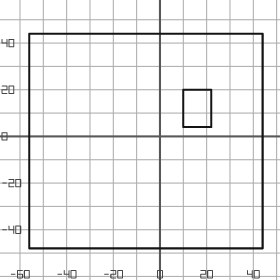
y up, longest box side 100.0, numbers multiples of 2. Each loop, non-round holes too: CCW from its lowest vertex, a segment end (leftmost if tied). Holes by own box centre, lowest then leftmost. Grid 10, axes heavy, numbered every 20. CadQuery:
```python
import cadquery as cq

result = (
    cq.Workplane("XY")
    .moveTo(-56.0, -48.0)
    .lineTo(44.0, -48.0)
    .lineTo(44.0, 44.0)
    .lineTo(-56.0, 44.0)
    .close()
    .moveTo(10.0, 4.0)
    .lineTo(22.0, 4.0)
    .lineTo(22.0, 20.0)
    .lineTo(10.0, 20.0)
    .close()
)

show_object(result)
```